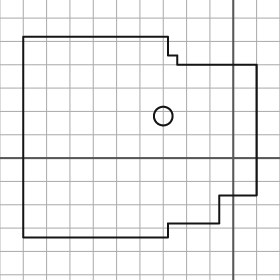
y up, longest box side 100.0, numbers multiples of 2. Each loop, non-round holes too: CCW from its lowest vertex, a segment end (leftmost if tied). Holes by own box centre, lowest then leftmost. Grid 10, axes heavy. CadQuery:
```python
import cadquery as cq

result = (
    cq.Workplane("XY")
    .moveTo(-90.0, -34.0)
    .lineTo(-28.0, -34.0)
    .lineTo(-28.0, -28.0)
    .lineTo(-6.0, -28.0)
    .lineTo(-6.0, -16.0)
    .lineTo(10.0, -16.0)
    .lineTo(10.0, 40.0)
    .lineTo(-24.0, 40.0)
    .lineTo(-24.0, 44.0)
    .lineTo(-28.0, 44.0)
    .lineTo(-28.0, 52.0)
    .lineTo(-90.0, 52.0)
    .close()
    .moveTo(-30.0, 18.0)
    .circle(4.0)
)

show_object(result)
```